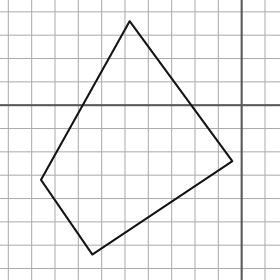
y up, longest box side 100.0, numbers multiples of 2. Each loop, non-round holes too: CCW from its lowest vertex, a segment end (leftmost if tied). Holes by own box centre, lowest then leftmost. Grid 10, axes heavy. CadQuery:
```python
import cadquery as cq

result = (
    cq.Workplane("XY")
    .moveTo(-64.0, -64.0)
    .lineTo(-4.0, -24.0)
    .lineTo(-48.0, 36.0)
    .lineTo(-86.0, -32.0)
    .close()
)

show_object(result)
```